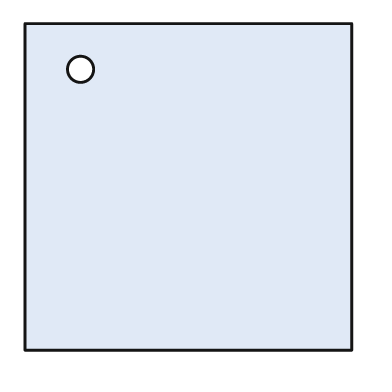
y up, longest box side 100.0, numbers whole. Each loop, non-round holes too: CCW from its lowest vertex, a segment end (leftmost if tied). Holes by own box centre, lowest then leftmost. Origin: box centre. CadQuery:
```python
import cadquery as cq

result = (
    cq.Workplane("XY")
    .moveTo(-50.0, -50.0)
    .lineTo(50.0, -50.0)
    .lineTo(50.0, 50.0)
    .lineTo(-50.0, 50.0)
    .close()
    .moveTo(-33.0, 36.0)
    .circle(4.0)
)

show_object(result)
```